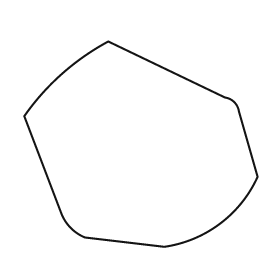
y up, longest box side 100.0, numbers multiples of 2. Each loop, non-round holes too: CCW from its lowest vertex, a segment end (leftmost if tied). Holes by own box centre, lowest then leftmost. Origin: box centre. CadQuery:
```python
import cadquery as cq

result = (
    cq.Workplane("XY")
    .moveTo(10.0, -44.0)
    .threePointArc((34.0, -34.0), (50.0, -14.0))
    .lineTo(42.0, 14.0)
    .threePointArc((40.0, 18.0), (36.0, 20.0))
    .lineTo(-14.0, 44.0)
    .threePointArc((-34.0, 30.0), (-50.0, 12.0))
    .lineTo(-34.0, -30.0)
    .threePointArc((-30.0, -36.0), (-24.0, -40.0))
    .close()
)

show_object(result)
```